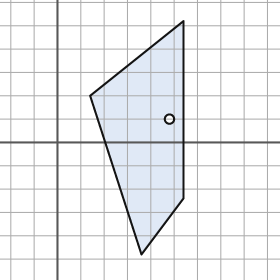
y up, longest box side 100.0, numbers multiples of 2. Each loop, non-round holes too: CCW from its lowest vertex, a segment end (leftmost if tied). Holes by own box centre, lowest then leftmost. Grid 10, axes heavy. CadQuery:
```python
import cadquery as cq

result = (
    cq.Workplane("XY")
    .moveTo(36.0, -48.0)
    .lineTo(54.0, -24.0)
    .lineTo(54.0, 52.0)
    .lineTo(14.0, 20.0)
    .close()
    .moveTo(48.0, 10.0)
    .circle(2.0)
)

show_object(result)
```